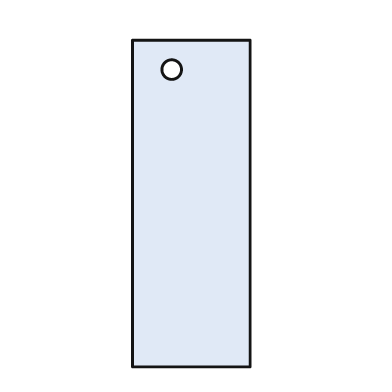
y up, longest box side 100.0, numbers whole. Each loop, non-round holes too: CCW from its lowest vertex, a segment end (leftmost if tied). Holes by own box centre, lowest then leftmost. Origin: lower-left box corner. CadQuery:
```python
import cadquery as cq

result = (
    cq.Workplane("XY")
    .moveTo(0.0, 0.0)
    .lineTo(36.0, 0.0)
    .lineTo(36.0, 100.0)
    .lineTo(0.0, 100.0)
    .close()
    .moveTo(12.0, 91.0)
    .circle(3.0)
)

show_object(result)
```